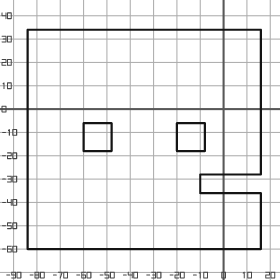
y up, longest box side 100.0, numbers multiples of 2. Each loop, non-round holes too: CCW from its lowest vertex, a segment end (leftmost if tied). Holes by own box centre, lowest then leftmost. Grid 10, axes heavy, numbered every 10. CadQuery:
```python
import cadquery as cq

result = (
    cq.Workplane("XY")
    .moveTo(-84.0, -60.0)
    .lineTo(16.0, -60.0)
    .lineTo(16.0, -36.0)
    .lineTo(-10.0, -36.0)
    .lineTo(-10.0, -28.0)
    .lineTo(16.0, -28.0)
    .lineTo(16.0, 34.0)
    .lineTo(-84.0, 34.0)
    .close()
    .moveTo(-60.0, -18.0)
    .lineTo(-48.0, -18.0)
    .lineTo(-48.0, -6.0)
    .lineTo(-60.0, -6.0)
    .close()
    .moveTo(-20.0, -18.0)
    .lineTo(-8.0, -18.0)
    .lineTo(-8.0, -6.0)
    .lineTo(-20.0, -6.0)
    .close()
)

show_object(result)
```